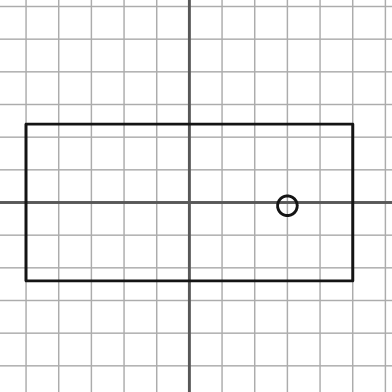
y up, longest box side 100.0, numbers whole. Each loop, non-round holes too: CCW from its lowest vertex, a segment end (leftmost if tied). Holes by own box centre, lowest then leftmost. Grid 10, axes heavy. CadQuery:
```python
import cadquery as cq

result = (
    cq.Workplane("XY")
    .moveTo(-50.0, -24.0)
    .lineTo(50.0, -24.0)
    .lineTo(50.0, 24.0)
    .lineTo(-50.0, 24.0)
    .close()
    .moveTo(30.0, -1.0)
    .circle(3.0)
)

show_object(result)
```